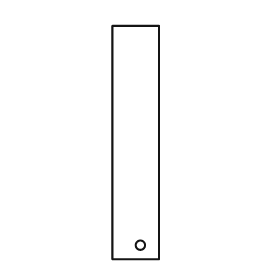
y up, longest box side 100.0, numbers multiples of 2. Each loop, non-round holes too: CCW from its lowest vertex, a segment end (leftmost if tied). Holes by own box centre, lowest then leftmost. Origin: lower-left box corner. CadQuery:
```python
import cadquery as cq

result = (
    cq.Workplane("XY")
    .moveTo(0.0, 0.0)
    .lineTo(20.0, 0.0)
    .lineTo(20.0, 100.0)
    .lineTo(0.0, 100.0)
    .close()
    .moveTo(12.0, 6.0)
    .circle(2.0)
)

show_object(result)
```